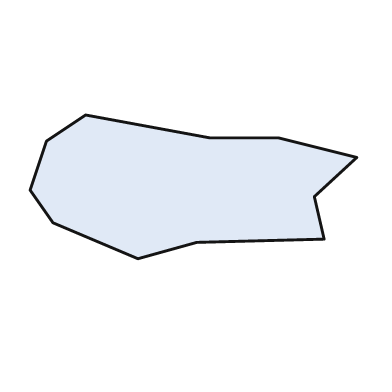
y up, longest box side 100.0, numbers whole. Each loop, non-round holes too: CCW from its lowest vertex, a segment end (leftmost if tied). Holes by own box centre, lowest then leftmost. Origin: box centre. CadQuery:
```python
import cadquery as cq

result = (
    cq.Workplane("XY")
    .moveTo(-17.0, -22.0)
    .lineTo(1.0, -17.0)
    .lineTo(40.0, -16.0)
    .lineTo(37.0, -3.0)
    .lineTo(50.0, 9.0)
    .lineTo(26.0, 15.0)
    .lineTo(5.0, 15.0)
    .lineTo(-33.0, 22.0)
    .lineTo(-45.0, 14.0)
    .lineTo(-50.0, -1.0)
    .lineTo(-43.0, -11.0)
    .close()
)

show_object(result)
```